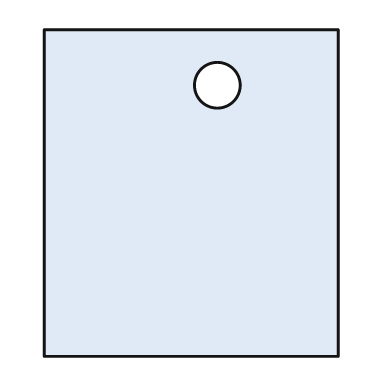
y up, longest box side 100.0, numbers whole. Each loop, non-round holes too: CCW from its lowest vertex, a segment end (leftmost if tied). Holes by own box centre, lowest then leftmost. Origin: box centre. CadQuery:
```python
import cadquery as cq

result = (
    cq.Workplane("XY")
    .moveTo(-45.0, -50.0)
    .lineTo(45.0, -50.0)
    .lineTo(45.0, 50.0)
    .lineTo(-45.0, 50.0)
    .close()
    .moveTo(8.0, 33.0)
    .circle(7.0)
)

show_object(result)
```